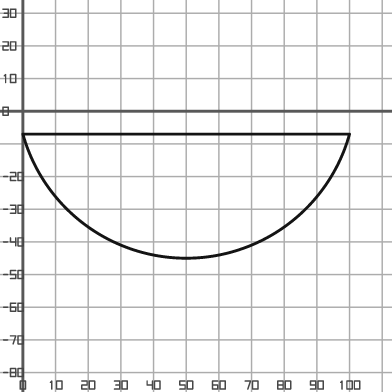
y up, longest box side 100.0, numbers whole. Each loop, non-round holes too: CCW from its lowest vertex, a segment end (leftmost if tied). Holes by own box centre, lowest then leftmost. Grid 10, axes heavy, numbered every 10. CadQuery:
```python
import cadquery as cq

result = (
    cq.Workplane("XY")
    .moveTo(0.0, -7.0)
    .threePointArc((50.0, -45.0), (100.0, -7.0))
    .close()
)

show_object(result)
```